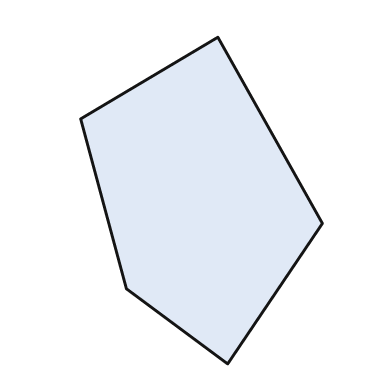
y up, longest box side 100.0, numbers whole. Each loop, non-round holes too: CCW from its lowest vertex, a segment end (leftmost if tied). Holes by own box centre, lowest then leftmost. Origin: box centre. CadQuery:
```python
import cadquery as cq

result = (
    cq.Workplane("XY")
    .moveTo(8.0, -50.0)
    .lineTo(37.0, -7.0)
    .lineTo(5.0, 50.0)
    .lineTo(-37.0, 25.0)
    .lineTo(-23.0, -27.0)
    .close()
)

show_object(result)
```